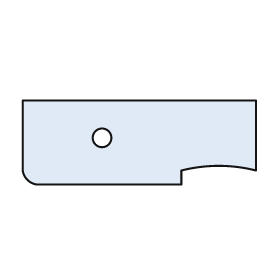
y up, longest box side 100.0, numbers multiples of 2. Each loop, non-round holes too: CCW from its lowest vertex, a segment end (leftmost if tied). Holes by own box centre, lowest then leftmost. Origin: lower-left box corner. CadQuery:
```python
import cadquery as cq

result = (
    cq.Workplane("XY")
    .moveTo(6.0, 0.0)
    .lineTo(68.0, 0.0)
    .lineTo(68.0, 6.0)
    .threePointArc((84.0, 8.0), (100.0, 6.0))
    .lineTo(100.0, 36.0)
    .lineTo(0.0, 36.0)
    .lineTo(0.0, 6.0)
    .threePointArc((2.0, 2.0), (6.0, 0.0))
    .close()
    .moveTo(34.0, 20.0)
    .circle(4.0)
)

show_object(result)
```